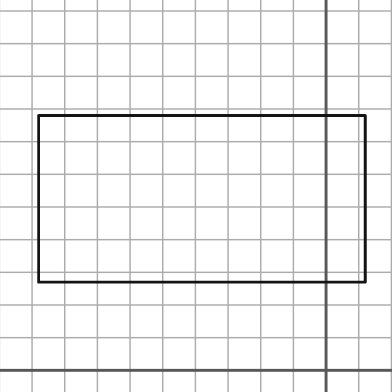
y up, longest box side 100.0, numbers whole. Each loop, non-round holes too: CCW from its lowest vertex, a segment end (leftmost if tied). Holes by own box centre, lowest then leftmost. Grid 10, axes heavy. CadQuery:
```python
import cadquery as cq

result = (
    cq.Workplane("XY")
    .moveTo(-88.0, 27.0)
    .lineTo(12.0, 27.0)
    .lineTo(12.0, 78.0)
    .lineTo(-88.0, 78.0)
    .close()
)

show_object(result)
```